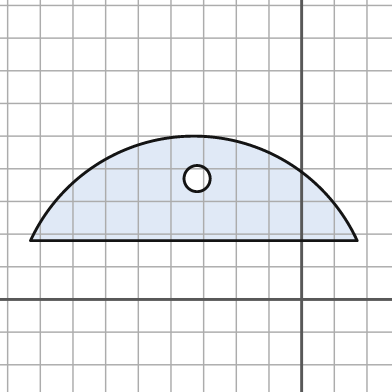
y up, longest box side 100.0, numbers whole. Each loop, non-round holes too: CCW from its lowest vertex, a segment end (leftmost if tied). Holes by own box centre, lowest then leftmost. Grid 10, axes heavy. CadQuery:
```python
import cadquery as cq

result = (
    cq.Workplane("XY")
    .moveTo(-83.0, 18.0)
    .lineTo(17.0, 18.0)
    .threePointArc((-33.0, 50.0), (-83.0, 18.0))
    .close()
    .moveTo(-32.0, 37.0)
    .circle(4.0)
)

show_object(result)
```